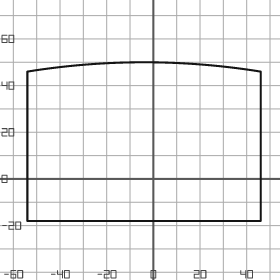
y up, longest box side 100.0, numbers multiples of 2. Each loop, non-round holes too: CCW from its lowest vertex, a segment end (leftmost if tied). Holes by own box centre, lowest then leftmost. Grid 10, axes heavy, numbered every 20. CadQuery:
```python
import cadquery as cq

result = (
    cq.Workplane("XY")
    .moveTo(-54.0, -18.0)
    .lineTo(46.0, -18.0)
    .lineTo(46.0, 46.0)
    .threePointArc((-4.0, 50.0), (-54.0, 46.0))
    .close()
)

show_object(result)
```